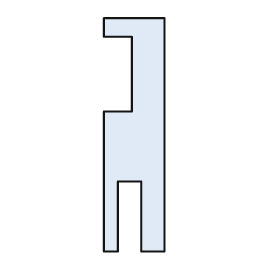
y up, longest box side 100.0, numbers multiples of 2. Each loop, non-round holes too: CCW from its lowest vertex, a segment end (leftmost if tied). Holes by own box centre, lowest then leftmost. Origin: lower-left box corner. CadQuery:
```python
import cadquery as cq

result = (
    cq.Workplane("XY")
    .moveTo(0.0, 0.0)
    .lineTo(6.0, 0.0)
    .lineTo(6.0, 30.0)
    .lineTo(16.0, 30.0)
    .lineTo(16.0, 0.0)
    .lineTo(26.0, 0.0)
    .lineTo(26.0, 100.0)
    .lineTo(0.0, 100.0)
    .lineTo(0.0, 92.0)
    .lineTo(12.0, 92.0)
    .lineTo(12.0, 60.0)
    .lineTo(0.0, 60.0)
    .close()
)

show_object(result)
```